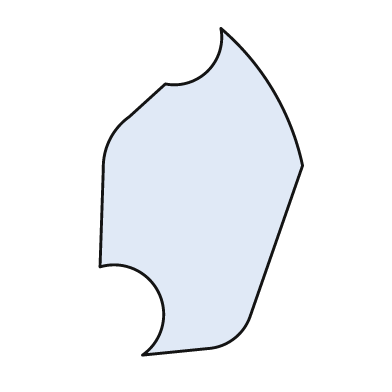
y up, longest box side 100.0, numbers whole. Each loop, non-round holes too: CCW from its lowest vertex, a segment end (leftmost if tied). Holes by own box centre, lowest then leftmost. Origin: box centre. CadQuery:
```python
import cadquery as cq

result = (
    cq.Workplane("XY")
    .moveTo(-18.0, -50.0)
    .lineTo(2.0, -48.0)
    .threePointArc((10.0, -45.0), (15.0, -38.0))
    .lineTo(31.0, 8.0)
    .threePointArc((22.0, 31.0), (6.0, 50.0))
    .threePointArc((2.0, 37.0), (-11.0, 33.0))
    .lineTo(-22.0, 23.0)
    .threePointArc((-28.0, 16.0), (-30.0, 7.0))
    .lineTo(-31.0, -23.0)
    .threePointArc((-13.0, -31.0), (-18.0, -50.0))
    .close()
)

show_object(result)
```